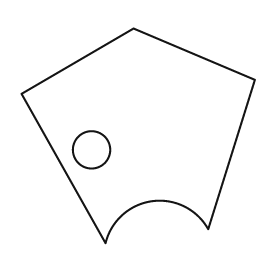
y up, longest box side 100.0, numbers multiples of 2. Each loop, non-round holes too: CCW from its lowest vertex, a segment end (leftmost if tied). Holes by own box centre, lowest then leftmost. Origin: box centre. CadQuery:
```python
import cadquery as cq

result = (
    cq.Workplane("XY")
    .moveTo(-14.0, -46.0)
    .threePointArc((6.0, -28.0), (30.0, -40.0))
    .lineTo(50.0, 24.0)
    .lineTo(-2.0, 46.0)
    .lineTo(-50.0, 18.0)
    .close()
    .moveTo(-20.0, -6.0)
    .circle(8.0)
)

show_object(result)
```